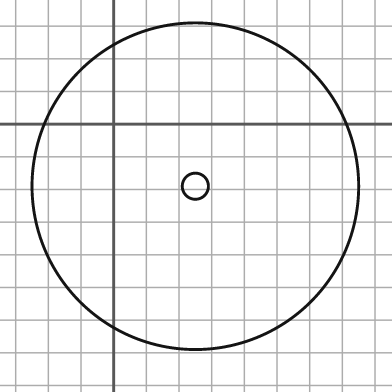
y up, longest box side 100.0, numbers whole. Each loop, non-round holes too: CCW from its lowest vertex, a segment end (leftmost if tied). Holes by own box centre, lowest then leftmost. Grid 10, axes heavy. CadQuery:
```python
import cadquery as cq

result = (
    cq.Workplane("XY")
    .moveTo(25.0, -19.0)
    .circle(50.0)
    .moveTo(25.0, -19.0)
    .circle(4.0)
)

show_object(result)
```